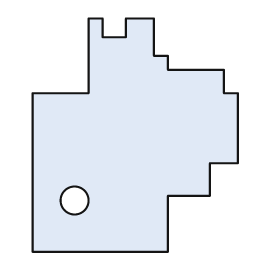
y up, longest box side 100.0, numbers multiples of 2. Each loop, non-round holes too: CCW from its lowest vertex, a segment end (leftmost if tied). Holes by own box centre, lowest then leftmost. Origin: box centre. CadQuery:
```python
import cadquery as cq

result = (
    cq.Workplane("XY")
    .moveTo(-44.0, -50.0)
    .lineTo(14.0, -50.0)
    .lineTo(14.0, -26.0)
    .lineTo(32.0, -26.0)
    .lineTo(32.0, -12.0)
    .lineTo(44.0, -12.0)
    .lineTo(44.0, 18.0)
    .lineTo(38.0, 18.0)
    .lineTo(38.0, 28.0)
    .lineTo(14.0, 28.0)
    .lineTo(14.0, 34.0)
    .lineTo(8.0, 34.0)
    .lineTo(8.0, 50.0)
    .lineTo(-4.0, 50.0)
    .lineTo(-4.0, 42.0)
    .lineTo(-14.0, 42.0)
    .lineTo(-14.0, 50.0)
    .lineTo(-20.0, 50.0)
    .lineTo(-20.0, 18.0)
    .lineTo(-44.0, 18.0)
    .close()
    .moveTo(-26.0, -28.0)
    .circle(6.0)
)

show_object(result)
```